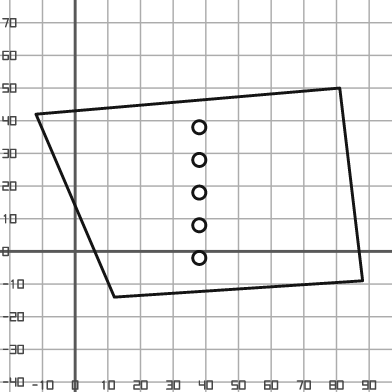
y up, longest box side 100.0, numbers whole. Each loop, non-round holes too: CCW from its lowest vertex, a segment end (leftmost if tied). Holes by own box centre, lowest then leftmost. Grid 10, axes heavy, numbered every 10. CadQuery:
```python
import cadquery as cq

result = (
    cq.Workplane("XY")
    .moveTo(12.0, -14.0)
    .lineTo(88.0, -9.0)
    .lineTo(81.0, 50.0)
    .lineTo(-12.0, 42.0)
    .close()
    .moveTo(38.0, -2.0)
    .circle(2.0)
    .moveTo(38.0, 8.0)
    .circle(2.0)
    .moveTo(38.0, 18.0)
    .circle(2.0)
    .moveTo(38.0, 28.0)
    .circle(2.0)
    .moveTo(38.0, 38.0)
    .circle(2.0)
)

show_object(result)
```